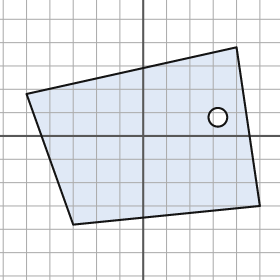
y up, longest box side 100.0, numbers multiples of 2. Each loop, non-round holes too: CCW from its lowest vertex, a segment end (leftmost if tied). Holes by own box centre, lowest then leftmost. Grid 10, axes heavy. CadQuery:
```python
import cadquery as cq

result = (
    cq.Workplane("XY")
    .moveTo(-30.0, -38.0)
    .lineTo(50.0, -30.0)
    .lineTo(40.0, 38.0)
    .lineTo(-50.0, 18.0)
    .close()
    .moveTo(32.0, 8.0)
    .circle(4.0)
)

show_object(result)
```